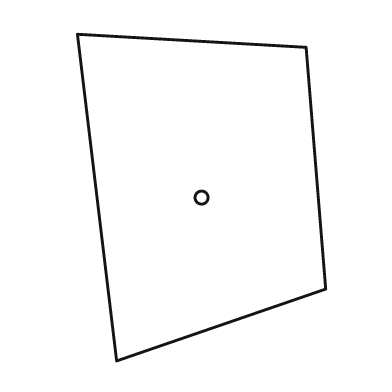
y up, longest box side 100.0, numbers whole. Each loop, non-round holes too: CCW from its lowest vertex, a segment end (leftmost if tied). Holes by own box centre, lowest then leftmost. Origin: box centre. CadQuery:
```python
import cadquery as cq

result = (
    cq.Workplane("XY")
    .moveTo(-26.0, -50.0)
    .lineTo(38.0, -28.0)
    .lineTo(32.0, 46.0)
    .lineTo(-38.0, 50.0)
    .close()
    .moveTo(0.0, 0.0)
    .circle(2.0)
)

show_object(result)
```